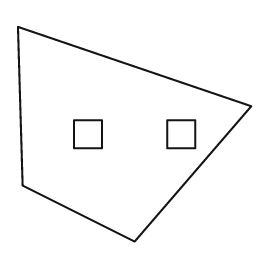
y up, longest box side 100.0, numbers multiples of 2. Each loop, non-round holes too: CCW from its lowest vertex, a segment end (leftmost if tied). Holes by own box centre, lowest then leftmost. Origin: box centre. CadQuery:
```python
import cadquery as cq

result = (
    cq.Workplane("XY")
    .moveTo(0.0, -46.0)
    .lineTo(50.0, 12.0)
    .lineTo(-50.0, 46.0)
    .lineTo(-48.0, -22.0)
    .close()
    .moveTo(-26.0, -6.0)
    .lineTo(-14.0, -6.0)
    .lineTo(-14.0, 6.0)
    .lineTo(-26.0, 6.0)
    .close()
    .moveTo(14.0, -6.0)
    .lineTo(26.0, -6.0)
    .lineTo(26.0, 6.0)
    .lineTo(14.0, 6.0)
    .close()
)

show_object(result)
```